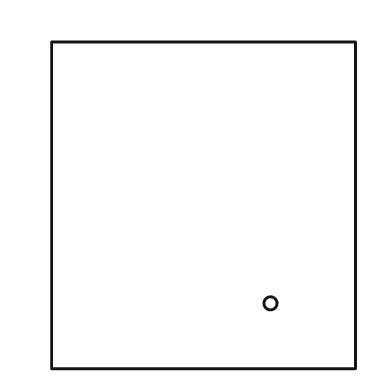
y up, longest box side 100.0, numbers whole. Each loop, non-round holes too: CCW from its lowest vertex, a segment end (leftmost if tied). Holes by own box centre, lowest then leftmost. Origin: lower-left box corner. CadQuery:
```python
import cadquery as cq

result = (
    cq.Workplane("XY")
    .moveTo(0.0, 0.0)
    .lineTo(93.0, 0.0)
    .lineTo(93.0, 100.0)
    .lineTo(0.0, 100.0)
    .close()
    .moveTo(67.0, 20.0)
    .circle(2.0)
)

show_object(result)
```